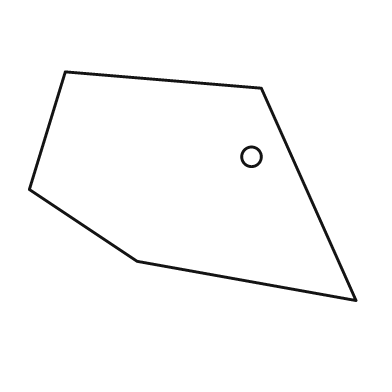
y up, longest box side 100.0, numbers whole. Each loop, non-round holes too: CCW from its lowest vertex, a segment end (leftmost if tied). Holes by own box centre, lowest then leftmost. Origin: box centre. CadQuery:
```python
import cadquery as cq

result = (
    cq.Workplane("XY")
    .moveTo(50.0, -35.0)
    .lineTo(21.0, 30.0)
    .lineTo(-39.0, 35.0)
    .lineTo(-50.0, -1.0)
    .lineTo(-17.0, -23.0)
    .close()
    .moveTo(18.0, 9.0)
    .circle(3.0)
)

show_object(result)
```